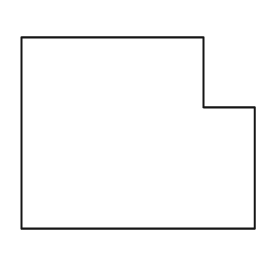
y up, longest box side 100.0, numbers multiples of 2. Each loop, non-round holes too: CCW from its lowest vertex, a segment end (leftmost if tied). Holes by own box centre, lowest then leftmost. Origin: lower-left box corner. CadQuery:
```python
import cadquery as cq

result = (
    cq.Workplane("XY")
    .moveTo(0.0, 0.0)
    .lineTo(100.0, 0.0)
    .lineTo(100.0, 52.0)
    .lineTo(78.0, 52.0)
    .lineTo(78.0, 82.0)
    .lineTo(0.0, 82.0)
    .close()
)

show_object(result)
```